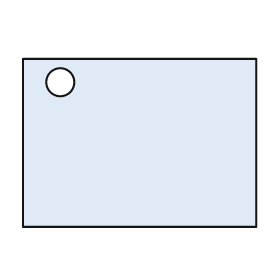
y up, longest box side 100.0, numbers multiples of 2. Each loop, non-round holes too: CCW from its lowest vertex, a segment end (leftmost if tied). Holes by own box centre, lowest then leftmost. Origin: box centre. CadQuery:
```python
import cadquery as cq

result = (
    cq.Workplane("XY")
    .moveTo(-50.0, -36.0)
    .lineTo(50.0, -36.0)
    .lineTo(50.0, 36.0)
    .lineTo(-50.0, 36.0)
    .close()
    .moveTo(-34.0, 26.0)
    .circle(6.0)
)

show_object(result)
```